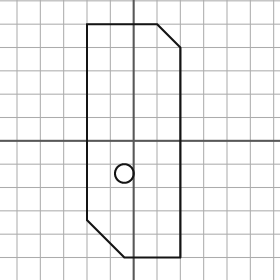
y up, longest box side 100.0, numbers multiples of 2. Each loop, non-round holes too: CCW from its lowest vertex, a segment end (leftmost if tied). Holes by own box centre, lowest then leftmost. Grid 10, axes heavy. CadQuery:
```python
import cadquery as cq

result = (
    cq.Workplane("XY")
    .moveTo(-4.0, -50.0)
    .lineTo(20.0, -50.0)
    .lineTo(20.0, 40.0)
    .lineTo(10.0, 50.0)
    .lineTo(-20.0, 50.0)
    .lineTo(-20.0, -34.0)
    .close()
    .moveTo(-4.0, -14.0)
    .circle(4.0)
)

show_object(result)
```